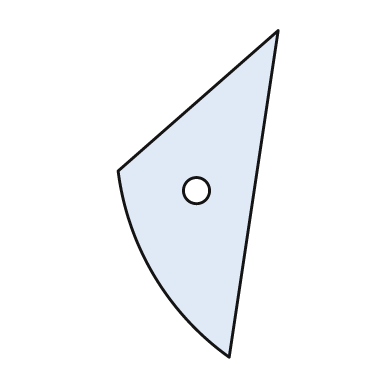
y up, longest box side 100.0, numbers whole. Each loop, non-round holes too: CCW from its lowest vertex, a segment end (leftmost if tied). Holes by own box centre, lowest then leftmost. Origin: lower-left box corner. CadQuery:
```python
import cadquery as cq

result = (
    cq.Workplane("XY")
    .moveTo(34.0, 0.0)
    .lineTo(49.0, 100.0)
    .lineTo(0.0, 57.0)
    .threePointArc((11.0, 25.0), (34.0, 0.0))
    .close()
    .moveTo(24.0, 51.0)
    .circle(4.0)
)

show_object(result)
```